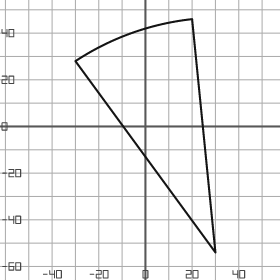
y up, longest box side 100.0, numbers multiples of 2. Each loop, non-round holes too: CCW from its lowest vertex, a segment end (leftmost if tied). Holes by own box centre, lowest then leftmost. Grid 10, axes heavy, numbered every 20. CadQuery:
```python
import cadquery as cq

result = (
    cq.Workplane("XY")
    .moveTo(30.0, -54.0)
    .lineTo(20.0, 46.0)
    .threePointArc((-6.0, 40.0), (-30.0, 28.0))
    .close()
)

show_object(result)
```